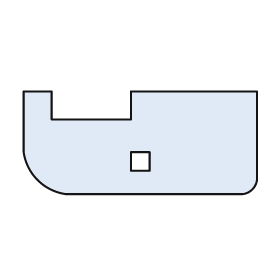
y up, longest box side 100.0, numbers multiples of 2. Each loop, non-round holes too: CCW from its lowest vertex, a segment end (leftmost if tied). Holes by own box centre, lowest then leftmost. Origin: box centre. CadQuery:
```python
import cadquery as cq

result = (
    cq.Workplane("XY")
    .moveTo(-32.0, -22.0)
    .lineTo(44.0, -22.0)
    .threePointArc((48.0, -20.0), (50.0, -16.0))
    .lineTo(50.0, 22.0)
    .lineTo(-4.0, 22.0)
    .lineTo(-4.0, 10.0)
    .lineTo(-38.0, 10.0)
    .lineTo(-38.0, 22.0)
    .lineTo(-50.0, 22.0)
    .lineTo(-50.0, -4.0)
    .threePointArc((-44.0, -16.0), (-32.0, -22.0))
    .close()
    .moveTo(-4.0, -12.0)
    .lineTo(4.0, -12.0)
    .lineTo(4.0, -4.0)
    .lineTo(-4.0, -4.0)
    .close()
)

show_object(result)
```